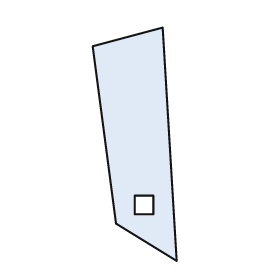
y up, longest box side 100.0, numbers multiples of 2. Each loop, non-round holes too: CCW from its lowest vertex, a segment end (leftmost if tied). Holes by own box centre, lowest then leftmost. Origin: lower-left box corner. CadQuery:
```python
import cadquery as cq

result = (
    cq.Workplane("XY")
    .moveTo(36.0, 0.0)
    .lineTo(30.0, 100.0)
    .lineTo(0.0, 92.0)
    .lineTo(10.0, 16.0)
    .close()
    .moveTo(18.0, 20.0)
    .lineTo(26.0, 20.0)
    .lineTo(26.0, 28.0)
    .lineTo(18.0, 28.0)
    .close()
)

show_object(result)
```